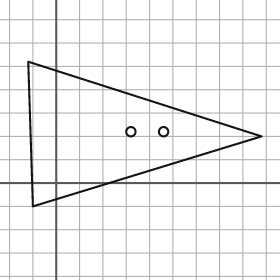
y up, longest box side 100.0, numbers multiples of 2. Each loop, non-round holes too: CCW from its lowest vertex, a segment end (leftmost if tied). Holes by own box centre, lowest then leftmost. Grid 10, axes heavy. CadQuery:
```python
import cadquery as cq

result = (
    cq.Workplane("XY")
    .moveTo(-10.0, -10.0)
    .lineTo(88.0, 20.0)
    .lineTo(-12.0, 52.0)
    .close()
    .moveTo(32.0, 22.0)
    .circle(2.0)
    .moveTo(46.0, 22.0)
    .circle(2.0)
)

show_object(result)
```